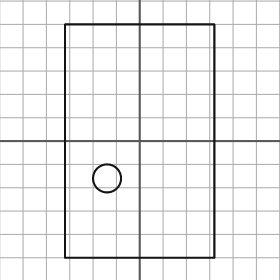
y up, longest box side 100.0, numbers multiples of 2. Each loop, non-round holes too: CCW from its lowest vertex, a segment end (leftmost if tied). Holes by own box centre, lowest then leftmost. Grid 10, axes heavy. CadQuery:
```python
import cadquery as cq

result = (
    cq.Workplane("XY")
    .moveTo(-32.0, -50.0)
    .lineTo(32.0, -50.0)
    .lineTo(32.0, 50.0)
    .lineTo(-32.0, 50.0)
    .close()
    .moveTo(-14.0, -16.0)
    .circle(6.0)
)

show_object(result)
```